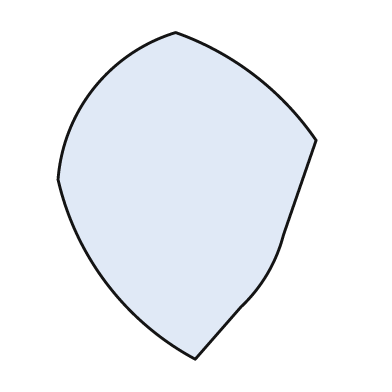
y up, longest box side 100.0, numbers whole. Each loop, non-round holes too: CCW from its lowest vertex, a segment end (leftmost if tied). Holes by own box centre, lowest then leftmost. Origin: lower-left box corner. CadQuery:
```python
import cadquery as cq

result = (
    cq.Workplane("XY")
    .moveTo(42.0, 0.0)
    .lineTo(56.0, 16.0)
    .threePointArc((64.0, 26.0), (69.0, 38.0))
    .lineTo(79.0, 67.0)
    .threePointArc((60.0, 87.0), (36.0, 100.0))
    .threePointArc((11.0, 83.0), (0.0, 55.0))
    .threePointArc((15.0, 23.0), (42.0, 0.0))
    .close()
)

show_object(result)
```